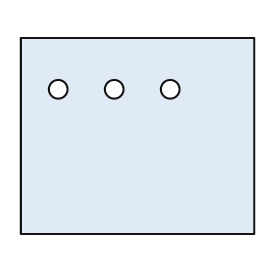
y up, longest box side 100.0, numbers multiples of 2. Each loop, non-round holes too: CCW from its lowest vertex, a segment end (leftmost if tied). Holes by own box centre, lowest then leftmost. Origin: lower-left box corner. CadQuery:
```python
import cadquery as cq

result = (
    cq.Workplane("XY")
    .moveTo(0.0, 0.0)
    .lineTo(100.0, 0.0)
    .lineTo(100.0, 84.0)
    .lineTo(0.0, 84.0)
    .close()
    .moveTo(16.0, 62.0)
    .circle(4.0)
    .moveTo(40.0, 62.0)
    .circle(4.0)
    .moveTo(64.0, 62.0)
    .circle(4.0)
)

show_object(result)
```